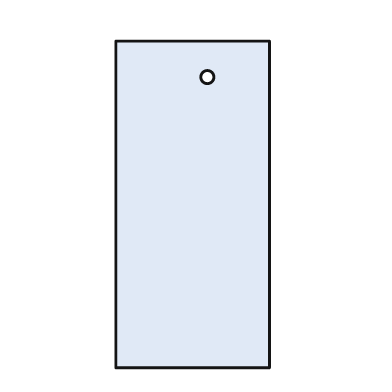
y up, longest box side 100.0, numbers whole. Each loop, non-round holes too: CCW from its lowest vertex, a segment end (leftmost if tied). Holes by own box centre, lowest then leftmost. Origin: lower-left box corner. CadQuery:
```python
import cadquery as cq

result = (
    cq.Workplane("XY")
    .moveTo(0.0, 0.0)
    .lineTo(47.0, 0.0)
    .lineTo(47.0, 100.0)
    .lineTo(0.0, 100.0)
    .close()
    .moveTo(28.0, 89.0)
    .circle(2.0)
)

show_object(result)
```